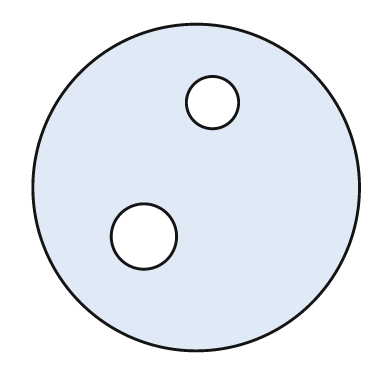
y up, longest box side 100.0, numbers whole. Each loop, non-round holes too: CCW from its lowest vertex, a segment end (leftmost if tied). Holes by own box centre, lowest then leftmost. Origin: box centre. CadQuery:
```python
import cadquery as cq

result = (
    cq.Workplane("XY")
    .moveTo(0.0, 0.0)
    .circle(50.0)
    .moveTo(-16.0, -15.0)
    .circle(10.0)
    .moveTo(5.0, 26.0)
    .circle(8.0)
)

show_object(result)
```